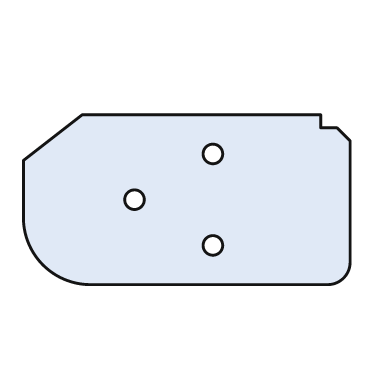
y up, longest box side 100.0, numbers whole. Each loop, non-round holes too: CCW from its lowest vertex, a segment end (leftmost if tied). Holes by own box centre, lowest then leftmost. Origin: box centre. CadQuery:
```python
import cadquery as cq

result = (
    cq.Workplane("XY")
    .moveTo(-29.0, -26.0)
    .lineTo(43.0, -26.0)
    .threePointArc((48.0, -24.0), (50.0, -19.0))
    .lineTo(50.0, 18.0)
    .lineTo(46.0, 22.0)
    .lineTo(41.0, 22.0)
    .lineTo(41.0, 26.0)
    .lineTo(-32.0, 26.0)
    .lineTo(-50.0, 12.0)
    .lineTo(-50.0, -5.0)
    .threePointArc((-44.0, -20.0), (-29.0, -26.0))
    .close()
    .moveTo(8.0, -14.0)
    .circle(3.0)
    .moveTo(-16.0, 0.0)
    .circle(3.0)
    .moveTo(8.0, 14.0)
    .circle(3.0)
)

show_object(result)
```